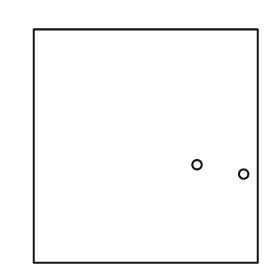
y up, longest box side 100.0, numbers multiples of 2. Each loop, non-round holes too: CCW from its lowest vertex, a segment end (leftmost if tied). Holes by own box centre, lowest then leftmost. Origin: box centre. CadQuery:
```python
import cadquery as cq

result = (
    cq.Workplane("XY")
    .moveTo(-48.0, -50.0)
    .lineTo(48.0, -50.0)
    .lineTo(48.0, 50.0)
    .lineTo(-48.0, 50.0)
    .close()
    .moveTo(42.0, -12.0)
    .circle(2.0)
    .moveTo(22.0, -8.0)
    .circle(2.0)
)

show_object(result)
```